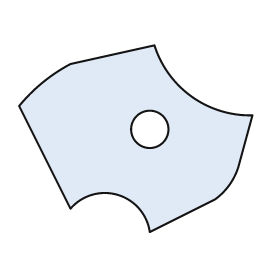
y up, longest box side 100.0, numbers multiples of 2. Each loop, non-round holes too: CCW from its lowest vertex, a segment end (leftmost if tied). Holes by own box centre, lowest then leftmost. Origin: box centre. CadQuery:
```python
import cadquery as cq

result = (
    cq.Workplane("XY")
    .moveTo(6.0, -40.0)
    .lineTo(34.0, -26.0)
    .threePointArc((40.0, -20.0), (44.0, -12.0))
    .lineTo(50.0, 10.0)
    .threePointArc((24.0, 18.0), (8.0, 40.0))
    .lineTo(-28.0, 32.0)
    .threePointArc((-40.0, 24.0), (-50.0, 14.0))
    .lineTo(-28.0, -30.0)
    .threePointArc((-8.0, -24.0), (6.0, -40.0))
    .close()
    .moveTo(6.0, 4.0)
    .circle(8.0)
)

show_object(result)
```